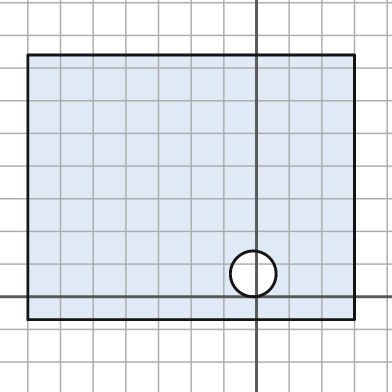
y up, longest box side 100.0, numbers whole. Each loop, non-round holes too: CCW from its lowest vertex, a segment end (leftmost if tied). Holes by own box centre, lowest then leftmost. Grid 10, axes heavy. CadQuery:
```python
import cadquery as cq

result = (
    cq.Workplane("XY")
    .moveTo(-70.0, -7.0)
    .lineTo(30.0, -7.0)
    .lineTo(30.0, 74.0)
    .lineTo(-70.0, 74.0)
    .close()
    .moveTo(-1.0, 7.0)
    .circle(7.0)
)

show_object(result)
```